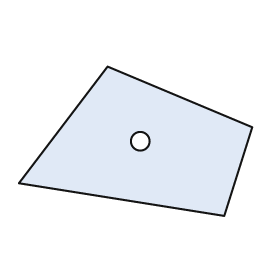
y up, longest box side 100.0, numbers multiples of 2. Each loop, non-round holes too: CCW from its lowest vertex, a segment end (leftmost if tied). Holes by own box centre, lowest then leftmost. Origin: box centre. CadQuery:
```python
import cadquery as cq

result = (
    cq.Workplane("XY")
    .moveTo(38.0, -32.0)
    .lineTo(50.0, 6.0)
    .lineTo(-12.0, 32.0)
    .lineTo(-50.0, -18.0)
    .close()
    .moveTo(2.0, 0.0)
    .circle(4.0)
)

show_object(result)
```